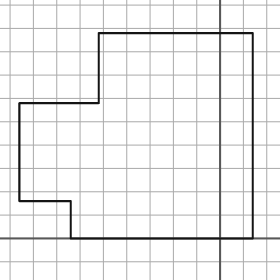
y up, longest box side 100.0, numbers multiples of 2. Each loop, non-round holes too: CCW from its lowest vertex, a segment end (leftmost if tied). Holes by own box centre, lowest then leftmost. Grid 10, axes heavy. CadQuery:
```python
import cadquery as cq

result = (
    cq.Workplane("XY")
    .moveTo(-64.0, 0.0)
    .lineTo(14.0, 0.0)
    .lineTo(14.0, 88.0)
    .lineTo(-52.0, 88.0)
    .lineTo(-52.0, 58.0)
    .lineTo(-86.0, 58.0)
    .lineTo(-86.0, 16.0)
    .lineTo(-64.0, 16.0)
    .close()
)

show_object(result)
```